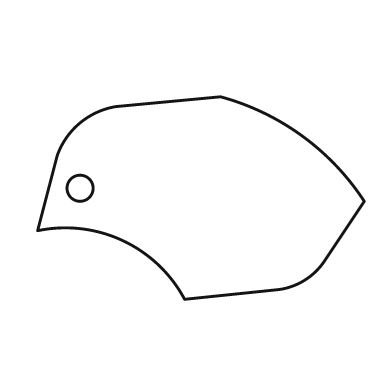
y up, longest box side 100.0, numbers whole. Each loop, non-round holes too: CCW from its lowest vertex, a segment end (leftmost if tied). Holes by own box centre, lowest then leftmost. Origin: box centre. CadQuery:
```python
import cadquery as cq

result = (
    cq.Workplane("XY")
    .moveTo(-5.0, -31.0)
    .lineTo(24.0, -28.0)
    .threePointArc((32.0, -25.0), (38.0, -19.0))
    .lineTo(50.0, -1.0)
    .threePointArc((31.0, 19.0), (6.0, 31.0))
    .lineTo(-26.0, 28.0)
    .threePointArc((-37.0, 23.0), (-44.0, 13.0))
    .lineTo(-50.0, -10.0)
    .threePointArc((-24.0, -13.0), (-5.0, -31.0))
    .close()
    .moveTo(-37.0, 3.0)
    .circle(4.0)
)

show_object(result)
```